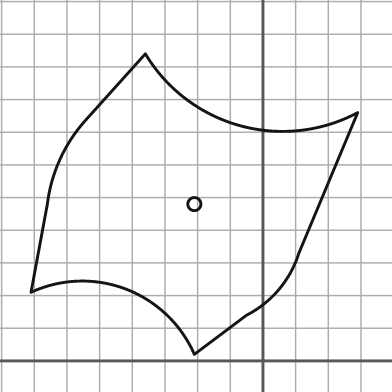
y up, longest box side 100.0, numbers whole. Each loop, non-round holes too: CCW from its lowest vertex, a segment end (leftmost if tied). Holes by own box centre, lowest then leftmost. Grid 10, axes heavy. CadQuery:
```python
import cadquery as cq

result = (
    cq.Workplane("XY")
    .moveTo(-21.0, 2.0)
    .lineTo(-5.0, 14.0)
    .threePointArc((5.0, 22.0), (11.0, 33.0))
    .lineTo(29.0, 76.0)
    .threePointArc((-7.0, 72.0), (-36.0, 94.0))
    .lineTo(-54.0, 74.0)
    .threePointArc((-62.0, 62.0), (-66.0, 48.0))
    .lineTo(-71.0, 21.0)
    .threePointArc((-42.0, 22.0), (-21.0, 2.0))
    .close()
    .moveTo(-21.0, 48.0)
    .circle(2.0)
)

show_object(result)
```